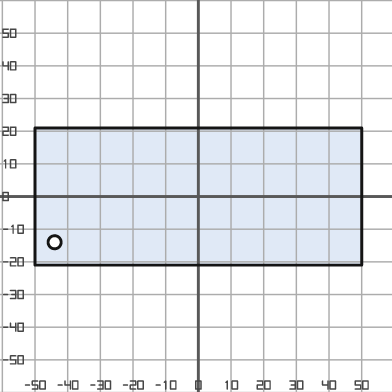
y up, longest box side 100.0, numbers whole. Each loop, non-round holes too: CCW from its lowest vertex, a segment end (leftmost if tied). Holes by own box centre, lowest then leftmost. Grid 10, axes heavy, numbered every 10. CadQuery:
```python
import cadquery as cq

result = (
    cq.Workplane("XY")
    .moveTo(-50.0, -21.0)
    .lineTo(50.0, -21.0)
    .lineTo(50.0, 21.0)
    .lineTo(-50.0, 21.0)
    .close()
    .moveTo(-44.0, -14.0)
    .circle(2.0)
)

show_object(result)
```